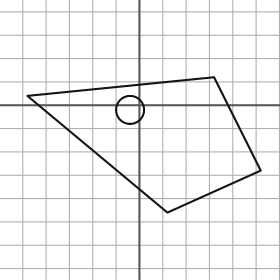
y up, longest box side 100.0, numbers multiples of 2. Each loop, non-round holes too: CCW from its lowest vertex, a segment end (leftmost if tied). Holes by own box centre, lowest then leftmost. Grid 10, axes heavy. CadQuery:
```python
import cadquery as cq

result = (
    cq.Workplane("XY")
    .moveTo(12.0, -46.0)
    .lineTo(52.0, -28.0)
    .lineTo(32.0, 12.0)
    .lineTo(-48.0, 4.0)
    .close()
    .moveTo(-4.0, -2.0)
    .circle(6.0)
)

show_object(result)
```